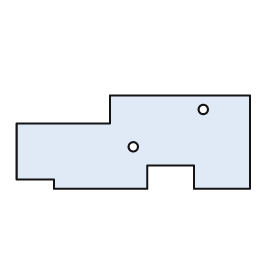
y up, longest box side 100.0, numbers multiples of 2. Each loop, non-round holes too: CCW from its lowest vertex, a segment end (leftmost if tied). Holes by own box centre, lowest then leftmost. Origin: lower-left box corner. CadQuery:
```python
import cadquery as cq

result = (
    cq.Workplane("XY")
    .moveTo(16.0, 0.0)
    .lineTo(56.0, 0.0)
    .lineTo(56.0, 10.0)
    .lineTo(76.0, 10.0)
    .lineTo(76.0, 0.0)
    .lineTo(100.0, 0.0)
    .lineTo(100.0, 40.0)
    .lineTo(40.0, 40.0)
    .lineTo(40.0, 28.0)
    .lineTo(0.0, 28.0)
    .lineTo(0.0, 4.0)
    .lineTo(16.0, 4.0)
    .close()
    .moveTo(50.0, 18.0)
    .circle(2.0)
    .moveTo(80.0, 34.0)
    .circle(2.0)
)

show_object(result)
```